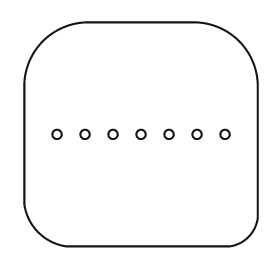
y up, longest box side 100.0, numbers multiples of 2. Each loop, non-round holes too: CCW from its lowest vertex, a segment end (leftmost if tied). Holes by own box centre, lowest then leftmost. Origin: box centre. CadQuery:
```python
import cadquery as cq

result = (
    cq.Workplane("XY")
    .moveTo(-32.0, -48.0)
    .lineTo(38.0, -48.0)
    .threePointArc((46.0, -44.0), (50.0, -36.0))
    .lineTo(50.0, 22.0)
    .threePointArc((42.0, 40.0), (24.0, 48.0))
    .lineTo(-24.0, 48.0)
    .threePointArc((-42.0, 40.0), (-50.0, 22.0))
    .lineTo(-50.0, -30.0)
    .threePointArc((-44.0, -42.0), (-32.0, -48.0))
    .close()
    .moveTo(-36.0, 0.0)
    .circle(2.0)
    .moveTo(-24.0, 0.0)
    .circle(2.0)
    .moveTo(-12.0, 0.0)
    .circle(2.0)
    .moveTo(0.0, 0.0)
    .circle(2.0)
    .moveTo(12.0, 0.0)
    .circle(2.0)
    .moveTo(24.0, 0.0)
    .circle(2.0)
    .moveTo(36.0, 0.0)
    .circle(2.0)
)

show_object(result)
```